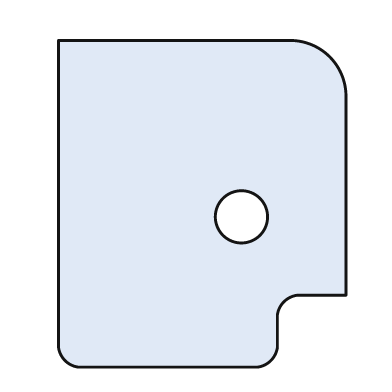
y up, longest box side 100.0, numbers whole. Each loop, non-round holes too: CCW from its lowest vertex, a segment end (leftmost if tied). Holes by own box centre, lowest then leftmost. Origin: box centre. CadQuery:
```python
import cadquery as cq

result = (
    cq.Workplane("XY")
    .moveTo(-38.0, -50.0)
    .lineTo(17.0, -50.0)
    .threePointArc((21.0, -48.0), (23.0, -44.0))
    .lineTo(23.0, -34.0)
    .threePointArc((25.0, -30.0), (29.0, -28.0))
    .lineTo(44.0, -28.0)
    .lineTo(44.0, 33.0)
    .threePointArc((39.0, 45.0), (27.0, 50.0))
    .lineTo(-44.0, 50.0)
    .lineTo(-44.0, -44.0)
    .threePointArc((-42.0, -48.0), (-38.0, -50.0))
    .close()
    .moveTo(12.0, -4.0)
    .circle(8.0)
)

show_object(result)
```